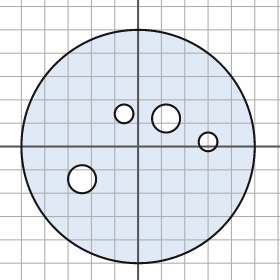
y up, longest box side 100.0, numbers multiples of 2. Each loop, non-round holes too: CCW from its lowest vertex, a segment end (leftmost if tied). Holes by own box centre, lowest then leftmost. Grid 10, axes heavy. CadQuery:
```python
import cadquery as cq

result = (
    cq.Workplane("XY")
    .moveTo(0.0, 0.0)
    .circle(50.0)
    .moveTo(-24.0, -14.0)
    .circle(6.0)
    .moveTo(30.0, 2.0)
    .circle(4.0)
    .moveTo(12.0, 12.0)
    .circle(6.0)
    .moveTo(-6.0, 14.0)
    .circle(4.0)
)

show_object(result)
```